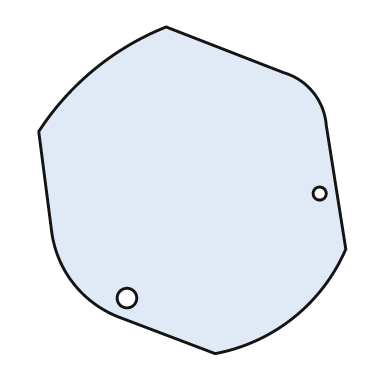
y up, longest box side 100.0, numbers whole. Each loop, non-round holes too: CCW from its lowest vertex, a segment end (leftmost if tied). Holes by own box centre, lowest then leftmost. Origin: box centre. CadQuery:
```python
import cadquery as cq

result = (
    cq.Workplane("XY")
    .moveTo(7.0, -50.0)
    .threePointArc((31.0, -39.0), (47.0, -18.0))
    .lineTo(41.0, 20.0)
    .threePointArc((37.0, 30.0), (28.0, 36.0))
    .lineTo(-8.0, 50.0)
    .threePointArc((-30.0, 37.0), (-47.0, 18.0))
    .lineTo(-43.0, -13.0)
    .threePointArc((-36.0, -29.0), (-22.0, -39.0))
    .close()
    .moveTo(-20.0, -33.0)
    .circle(3.0)
    .moveTo(39.0, -1.0)
    .circle(2.0)
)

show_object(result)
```